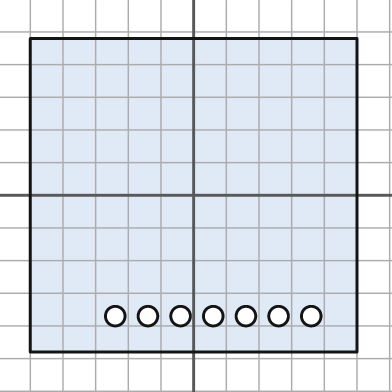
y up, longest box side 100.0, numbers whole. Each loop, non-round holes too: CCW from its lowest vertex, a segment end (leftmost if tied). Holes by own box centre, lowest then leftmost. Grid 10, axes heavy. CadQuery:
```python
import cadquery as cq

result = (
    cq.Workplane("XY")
    .moveTo(-50.0, -48.0)
    .lineTo(50.0, -48.0)
    .lineTo(50.0, 48.0)
    .lineTo(-50.0, 48.0)
    .close()
    .moveTo(-24.0, -37.0)
    .circle(3.0)
    .moveTo(-14.0, -37.0)
    .circle(3.0)
    .moveTo(-4.0, -37.0)
    .circle(3.0)
    .moveTo(6.0, -37.0)
    .circle(3.0)
    .moveTo(16.0, -37.0)
    .circle(3.0)
    .moveTo(26.0, -37.0)
    .circle(3.0)
    .moveTo(36.0, -37.0)
    .circle(3.0)
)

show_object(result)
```